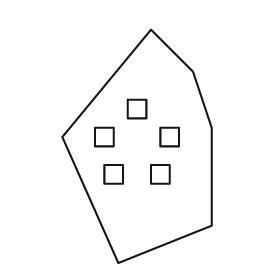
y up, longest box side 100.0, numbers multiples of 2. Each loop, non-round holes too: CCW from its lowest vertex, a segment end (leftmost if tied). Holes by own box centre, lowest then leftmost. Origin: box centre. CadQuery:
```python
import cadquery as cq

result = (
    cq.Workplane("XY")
    .moveTo(-8.0, -50.0)
    .lineTo(32.0, -34.0)
    .lineTo(32.0, 8.0)
    .lineTo(24.0, 32.0)
    .lineTo(6.0, 50.0)
    .lineTo(-32.0, 4.0)
    .close()
    .moveTo(-14.0, -16.0)
    .lineTo(-6.0, -16.0)
    .lineTo(-6.0, -8.0)
    .lineTo(-14.0, -8.0)
    .close()
    .moveTo(6.0, -16.0)
    .lineTo(14.0, -16.0)
    .lineTo(14.0, -8.0)
    .lineTo(6.0, -8.0)
    .close()
    .moveTo(-18.0, 0.0)
    .lineTo(-10.0, 0.0)
    .lineTo(-10.0, 8.0)
    .lineTo(-18.0, 8.0)
    .close()
    .moveTo(10.0, 0.0)
    .lineTo(18.0, 0.0)
    .lineTo(18.0, 8.0)
    .lineTo(10.0, 8.0)
    .close()
    .moveTo(-4.0, 12.0)
    .lineTo(4.0, 12.0)
    .lineTo(4.0, 20.0)
    .lineTo(-4.0, 20.0)
    .close()
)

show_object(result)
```